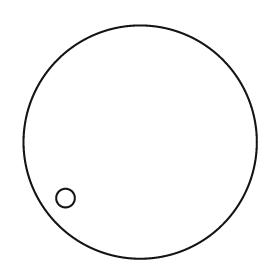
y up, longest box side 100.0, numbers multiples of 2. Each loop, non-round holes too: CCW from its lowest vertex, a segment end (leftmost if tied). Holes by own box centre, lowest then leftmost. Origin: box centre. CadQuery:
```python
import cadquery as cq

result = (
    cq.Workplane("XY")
    .moveTo(0.0, 0.0)
    .circle(50.0)
    .moveTo(-32.0, -24.0)
    .circle(4.0)
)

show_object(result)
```